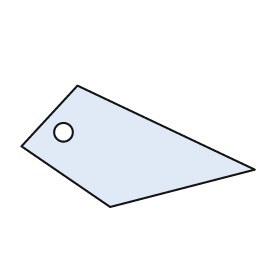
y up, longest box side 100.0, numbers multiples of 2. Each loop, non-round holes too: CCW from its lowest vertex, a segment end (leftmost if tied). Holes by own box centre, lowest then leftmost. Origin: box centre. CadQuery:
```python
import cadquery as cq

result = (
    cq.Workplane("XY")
    .moveTo(-12.0, -26.0)
    .lineTo(50.0, -10.0)
    .lineTo(-26.0, 26.0)
    .lineTo(-50.0, 0.0)
    .close()
    .moveTo(-32.0, 6.0)
    .circle(4.0)
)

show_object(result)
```